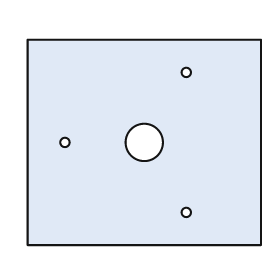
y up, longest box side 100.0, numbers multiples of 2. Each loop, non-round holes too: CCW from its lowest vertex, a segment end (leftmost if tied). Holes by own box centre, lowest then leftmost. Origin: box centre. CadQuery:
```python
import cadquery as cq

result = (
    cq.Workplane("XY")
    .moveTo(-50.0, -44.0)
    .lineTo(50.0, -44.0)
    .lineTo(50.0, 44.0)
    .lineTo(-50.0, 44.0)
    .close()
    .moveTo(18.0, -30.0)
    .circle(2.0)
    .moveTo(-34.0, 0.0)
    .circle(2.0)
    .moveTo(0.0, 0.0)
    .circle(8.0)
    .moveTo(18.0, 30.0)
    .circle(2.0)
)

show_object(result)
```